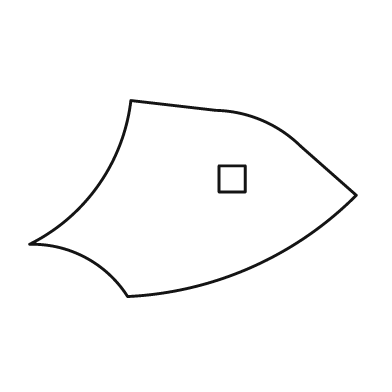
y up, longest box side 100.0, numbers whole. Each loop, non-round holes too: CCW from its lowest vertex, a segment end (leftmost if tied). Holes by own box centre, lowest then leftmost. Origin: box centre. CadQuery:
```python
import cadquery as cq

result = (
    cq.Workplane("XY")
    .moveTo(-20.0, -30.0)
    .threePointArc((18.0, -21.0), (50.0, 1.0))
    .lineTo(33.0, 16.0)
    .threePointArc((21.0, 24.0), (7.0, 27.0))
    .lineTo(-19.0, 30.0)
    .threePointArc((-29.0, 4.0), (-50.0, -14.0))
    .threePointArc((-33.0, -18.0), (-20.0, -30.0))
    .close()
    .moveTo(8.0, 2.0)
    .lineTo(16.0, 2.0)
    .lineTo(16.0, 10.0)
    .lineTo(8.0, 10.0)
    .close()
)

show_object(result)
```